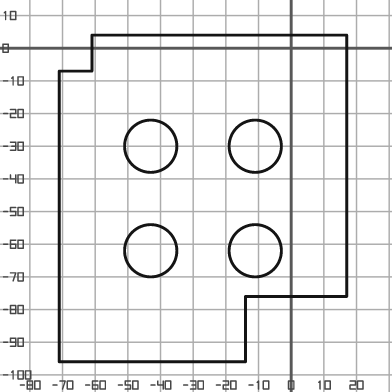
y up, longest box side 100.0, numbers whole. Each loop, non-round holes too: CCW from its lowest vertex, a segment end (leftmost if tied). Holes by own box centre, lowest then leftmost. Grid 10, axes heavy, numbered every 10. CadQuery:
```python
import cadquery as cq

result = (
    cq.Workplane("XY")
    .moveTo(-71.0, -96.0)
    .lineTo(-14.0, -96.0)
    .lineTo(-14.0, -76.0)
    .lineTo(17.0, -76.0)
    .lineTo(17.0, 4.0)
    .lineTo(-61.0, 4.0)
    .lineTo(-61.0, -7.0)
    .lineTo(-71.0, -7.0)
    .close()
    .moveTo(-43.0, -62.0)
    .circle(8.0)
    .moveTo(-11.0, -62.0)
    .circle(8.0)
    .moveTo(-43.0, -30.0)
    .circle(8.0)
    .moveTo(-11.0, -30.0)
    .circle(8.0)
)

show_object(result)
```